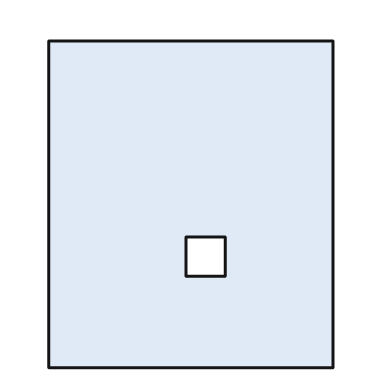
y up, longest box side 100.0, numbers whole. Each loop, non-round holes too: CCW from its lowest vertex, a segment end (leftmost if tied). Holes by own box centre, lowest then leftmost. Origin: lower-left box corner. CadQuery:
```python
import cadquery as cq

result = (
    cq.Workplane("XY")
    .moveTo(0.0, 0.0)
    .lineTo(87.0, 0.0)
    .lineTo(87.0, 100.0)
    .lineTo(0.0, 100.0)
    .close()
    .moveTo(42.0, 28.0)
    .lineTo(54.0, 28.0)
    .lineTo(54.0, 40.0)
    .lineTo(42.0, 40.0)
    .close()
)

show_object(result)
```